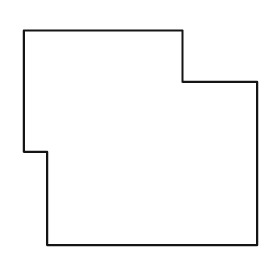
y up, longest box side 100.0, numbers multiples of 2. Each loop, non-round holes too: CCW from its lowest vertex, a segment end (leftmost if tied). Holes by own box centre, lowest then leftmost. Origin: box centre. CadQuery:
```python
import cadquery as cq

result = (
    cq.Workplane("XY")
    .moveTo(-40.0, -46.0)
    .lineTo(50.0, -46.0)
    .lineTo(50.0, 24.0)
    .lineTo(18.0, 24.0)
    .lineTo(18.0, 46.0)
    .lineTo(-50.0, 46.0)
    .lineTo(-50.0, -6.0)
    .lineTo(-40.0, -6.0)
    .close()
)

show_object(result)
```